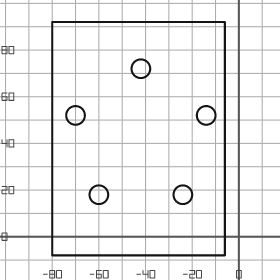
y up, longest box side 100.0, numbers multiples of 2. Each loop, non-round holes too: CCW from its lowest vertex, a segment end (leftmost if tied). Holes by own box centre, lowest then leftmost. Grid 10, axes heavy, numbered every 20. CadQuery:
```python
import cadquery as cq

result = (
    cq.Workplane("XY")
    .moveTo(-80.0, -8.0)
    .lineTo(-6.0, -8.0)
    .lineTo(-6.0, 92.0)
    .lineTo(-80.0, 92.0)
    .close()
    .moveTo(-60.0, 18.0)
    .circle(4.0)
    .moveTo(-24.0, 18.0)
    .circle(4.0)
    .moveTo(-70.0, 52.0)
    .circle(4.0)
    .moveTo(-14.0, 52.0)
    .circle(4.0)
    .moveTo(-42.0, 72.0)
    .circle(4.0)
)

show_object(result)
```